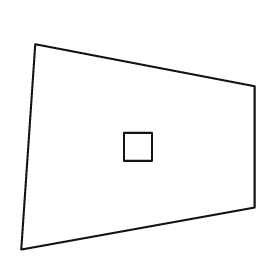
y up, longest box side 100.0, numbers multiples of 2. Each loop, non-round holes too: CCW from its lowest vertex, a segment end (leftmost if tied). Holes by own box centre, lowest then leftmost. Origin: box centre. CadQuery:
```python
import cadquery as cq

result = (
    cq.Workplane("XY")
    .moveTo(-50.0, -44.0)
    .lineTo(50.0, -26.0)
    .lineTo(50.0, 26.0)
    .lineTo(-44.0, 44.0)
    .close()
    .moveTo(-6.0, -6.0)
    .lineTo(6.0, -6.0)
    .lineTo(6.0, 6.0)
    .lineTo(-6.0, 6.0)
    .close()
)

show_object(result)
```